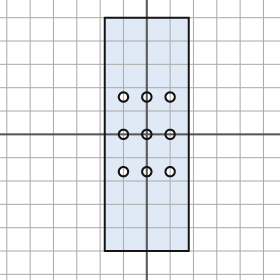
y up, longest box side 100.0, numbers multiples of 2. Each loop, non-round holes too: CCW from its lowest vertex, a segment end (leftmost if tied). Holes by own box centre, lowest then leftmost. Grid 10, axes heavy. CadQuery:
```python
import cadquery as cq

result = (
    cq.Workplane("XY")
    .moveTo(-18.0, -50.0)
    .lineTo(18.0, -50.0)
    .lineTo(18.0, 50.0)
    .lineTo(-18.0, 50.0)
    .close()
    .moveTo(-10.0, -16.0)
    .circle(2.0)
    .moveTo(0.0, -16.0)
    .circle(2.0)
    .moveTo(10.0, -16.0)
    .circle(2.0)
    .moveTo(-10.0, 0.0)
    .circle(2.0)
    .moveTo(0.0, 0.0)
    .circle(2.0)
    .moveTo(10.0, 0.0)
    .circle(2.0)
    .moveTo(-10.0, 16.0)
    .circle(2.0)
    .moveTo(0.0, 16.0)
    .circle(2.0)
    .moveTo(10.0, 16.0)
    .circle(2.0)
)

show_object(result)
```